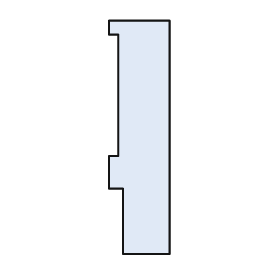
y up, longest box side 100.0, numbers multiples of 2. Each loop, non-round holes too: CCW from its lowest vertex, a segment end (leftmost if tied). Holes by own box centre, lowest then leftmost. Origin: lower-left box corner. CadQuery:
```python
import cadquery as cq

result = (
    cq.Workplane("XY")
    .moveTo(6.0, 0.0)
    .lineTo(26.0, 0.0)
    .lineTo(26.0, 100.0)
    .lineTo(0.0, 100.0)
    .lineTo(0.0, 94.0)
    .lineTo(4.0, 94.0)
    .lineTo(4.0, 42.0)
    .lineTo(0.0, 42.0)
    .lineTo(0.0, 28.0)
    .lineTo(6.0, 28.0)
    .close()
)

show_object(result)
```